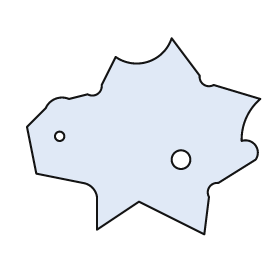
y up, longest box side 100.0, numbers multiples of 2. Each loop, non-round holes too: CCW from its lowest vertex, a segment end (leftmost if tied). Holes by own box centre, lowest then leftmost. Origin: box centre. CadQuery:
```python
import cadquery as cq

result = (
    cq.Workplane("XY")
    .moveTo(26.0, -42.0)
    .lineTo(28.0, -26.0)
    .threePointArc((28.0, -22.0), (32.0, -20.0))
    .lineTo(48.0, -10.0)
    .threePointArc((48.0, -4.0), (42.0, -2.0))
    .threePointArc((44.0, 8.0), (50.0, 16.0))
    .lineTo(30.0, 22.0)
    .threePointArc((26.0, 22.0), (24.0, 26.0))
    .lineTo(12.0, 42.0)
    .threePointArc((2.0, 32.0), (-12.0, 34.0))
    .lineTo(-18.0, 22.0)
    .threePointArc((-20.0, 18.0), (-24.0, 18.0))
    .lineTo(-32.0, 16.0)
    .threePointArc((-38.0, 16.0), (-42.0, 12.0))
    .lineTo(-50.0, 4.0)
    .lineTo(-46.0, -16.0)
    .lineTo(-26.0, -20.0)
    .threePointArc((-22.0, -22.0), (-20.0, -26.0))
    .lineTo(-20.0, -40.0)
    .lineTo(-2.0, -28.0)
    .close()
    .moveTo(16.0, -10.0)
    .circle(4.0)
    .moveTo(-36.0, 0.0)
    .circle(2.0)
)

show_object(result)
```